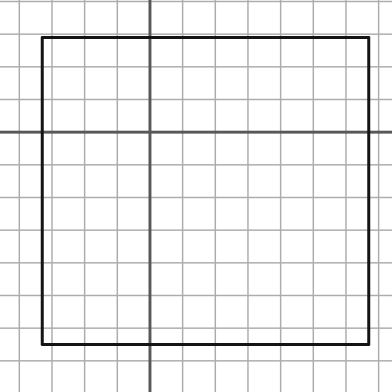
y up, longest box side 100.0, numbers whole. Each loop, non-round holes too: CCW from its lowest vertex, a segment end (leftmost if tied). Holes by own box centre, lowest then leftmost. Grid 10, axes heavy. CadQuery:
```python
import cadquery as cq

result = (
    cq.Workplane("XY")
    .moveTo(-33.0, -65.0)
    .lineTo(67.0, -65.0)
    .lineTo(67.0, 29.0)
    .lineTo(-33.0, 29.0)
    .close()
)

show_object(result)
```